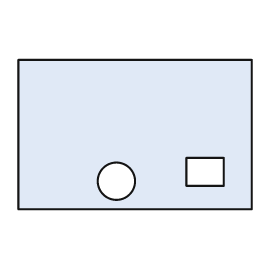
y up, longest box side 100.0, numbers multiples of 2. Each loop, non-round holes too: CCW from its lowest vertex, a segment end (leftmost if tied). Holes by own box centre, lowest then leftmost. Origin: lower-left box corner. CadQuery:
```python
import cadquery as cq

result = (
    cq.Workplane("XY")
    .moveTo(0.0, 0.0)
    .lineTo(100.0, 0.0)
    .lineTo(100.0, 64.0)
    .lineTo(0.0, 64.0)
    .close()
    .moveTo(42.0, 12.0)
    .circle(8.0)
    .moveTo(72.0, 10.0)
    .lineTo(88.0, 10.0)
    .lineTo(88.0, 22.0)
    .lineTo(72.0, 22.0)
    .close()
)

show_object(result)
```